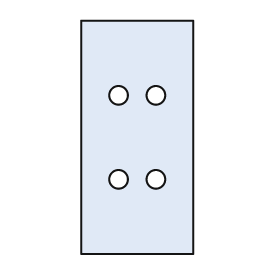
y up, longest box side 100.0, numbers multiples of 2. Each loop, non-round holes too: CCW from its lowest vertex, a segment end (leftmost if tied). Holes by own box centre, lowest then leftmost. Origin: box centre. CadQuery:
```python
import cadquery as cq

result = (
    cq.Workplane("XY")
    .moveTo(-24.0, -50.0)
    .lineTo(24.0, -50.0)
    .lineTo(24.0, 50.0)
    .lineTo(-24.0, 50.0)
    .close()
    .moveTo(-8.0, -18.0)
    .circle(4.0)
    .moveTo(8.0, -18.0)
    .circle(4.0)
    .moveTo(-8.0, 18.0)
    .circle(4.0)
    .moveTo(8.0, 18.0)
    .circle(4.0)
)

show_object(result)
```